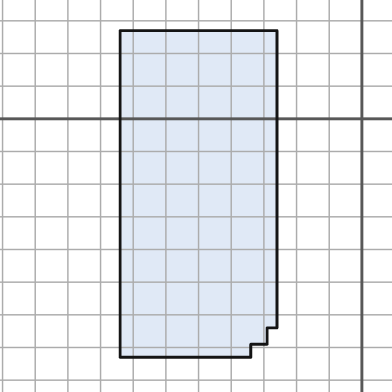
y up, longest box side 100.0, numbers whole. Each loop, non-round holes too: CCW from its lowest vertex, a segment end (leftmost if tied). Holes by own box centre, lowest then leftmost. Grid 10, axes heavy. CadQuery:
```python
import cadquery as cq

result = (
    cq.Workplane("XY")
    .moveTo(-74.0, -73.0)
    .lineTo(-34.0, -73.0)
    .lineTo(-34.0, -69.0)
    .lineTo(-29.0, -69.0)
    .lineTo(-29.0, -64.0)
    .lineTo(-26.0, -64.0)
    .lineTo(-26.0, 27.0)
    .lineTo(-74.0, 27.0)
    .close()
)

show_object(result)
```